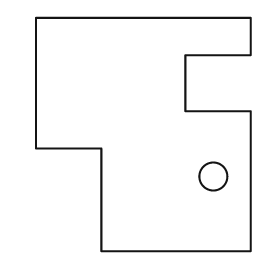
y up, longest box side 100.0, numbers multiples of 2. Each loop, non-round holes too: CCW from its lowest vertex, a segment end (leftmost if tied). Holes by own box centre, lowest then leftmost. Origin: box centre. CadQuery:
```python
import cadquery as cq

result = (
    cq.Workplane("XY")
    .moveTo(-18.0, -50.0)
    .lineTo(46.0, -50.0)
    .lineTo(46.0, 10.0)
    .lineTo(18.0, 10.0)
    .lineTo(18.0, 34.0)
    .lineTo(46.0, 34.0)
    .lineTo(46.0, 50.0)
    .lineTo(-46.0, 50.0)
    .lineTo(-46.0, -6.0)
    .lineTo(-18.0, -6.0)
    .close()
    .moveTo(30.0, -18.0)
    .circle(6.0)
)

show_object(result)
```